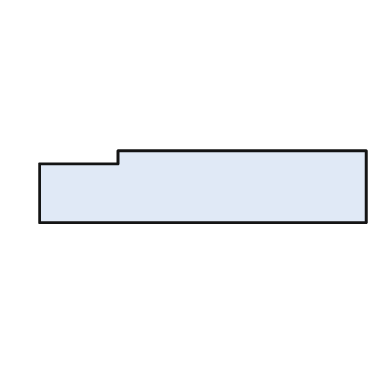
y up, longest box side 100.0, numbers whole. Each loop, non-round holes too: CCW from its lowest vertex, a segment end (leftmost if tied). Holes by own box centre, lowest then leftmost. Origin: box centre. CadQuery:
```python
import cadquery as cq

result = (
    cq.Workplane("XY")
    .moveTo(-50.0, -11.0)
    .lineTo(50.0, -11.0)
    .lineTo(50.0, 11.0)
    .lineTo(-26.0, 11.0)
    .lineTo(-26.0, 7.0)
    .lineTo(-50.0, 7.0)
    .close()
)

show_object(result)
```